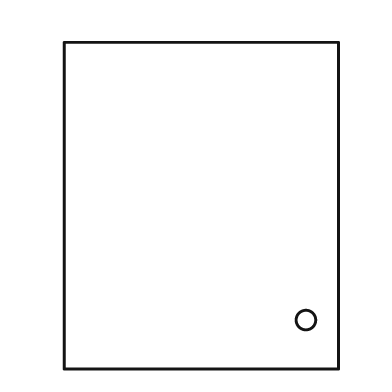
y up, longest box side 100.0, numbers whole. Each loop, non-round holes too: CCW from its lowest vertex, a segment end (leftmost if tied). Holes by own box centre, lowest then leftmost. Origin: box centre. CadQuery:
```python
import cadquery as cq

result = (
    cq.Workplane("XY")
    .moveTo(-42.0, -50.0)
    .lineTo(42.0, -50.0)
    .lineTo(42.0, 50.0)
    .lineTo(-42.0, 50.0)
    .close()
    .moveTo(32.0, -35.0)
    .circle(3.0)
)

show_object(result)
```